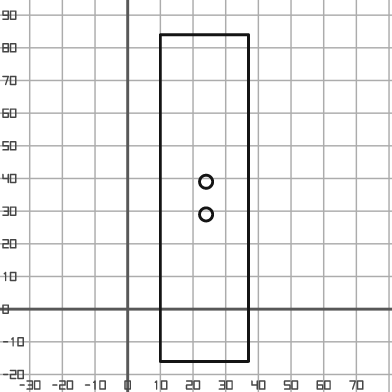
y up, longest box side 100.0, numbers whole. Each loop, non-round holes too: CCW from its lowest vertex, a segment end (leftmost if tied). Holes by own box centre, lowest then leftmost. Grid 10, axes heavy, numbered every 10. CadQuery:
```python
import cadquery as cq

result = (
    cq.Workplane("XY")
    .moveTo(10.0, -16.0)
    .lineTo(37.0, -16.0)
    .lineTo(37.0, 84.0)
    .lineTo(10.0, 84.0)
    .close()
    .moveTo(24.0, 29.0)
    .circle(2.0)
    .moveTo(24.0, 39.0)
    .circle(2.0)
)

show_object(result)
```